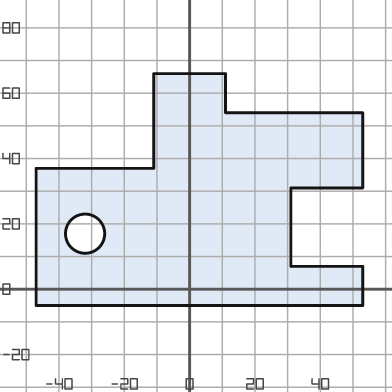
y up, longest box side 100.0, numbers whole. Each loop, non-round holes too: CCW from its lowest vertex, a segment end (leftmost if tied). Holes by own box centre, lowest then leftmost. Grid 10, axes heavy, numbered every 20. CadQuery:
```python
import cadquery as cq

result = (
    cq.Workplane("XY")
    .moveTo(-47.0, -5.0)
    .lineTo(53.0, -5.0)
    .lineTo(53.0, 7.0)
    .lineTo(31.0, 7.0)
    .lineTo(31.0, 31.0)
    .lineTo(53.0, 31.0)
    .lineTo(53.0, 54.0)
    .lineTo(11.0, 54.0)
    .lineTo(11.0, 66.0)
    .lineTo(-11.0, 66.0)
    .lineTo(-11.0, 37.0)
    .lineTo(-47.0, 37.0)
    .close()
    .moveTo(-32.0, 17.0)
    .circle(6.0)
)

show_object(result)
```